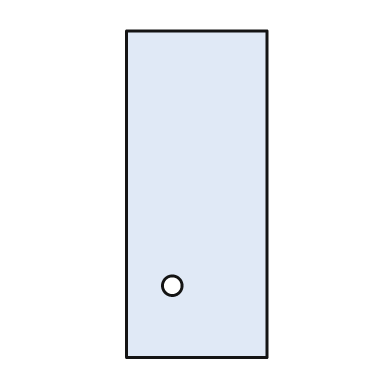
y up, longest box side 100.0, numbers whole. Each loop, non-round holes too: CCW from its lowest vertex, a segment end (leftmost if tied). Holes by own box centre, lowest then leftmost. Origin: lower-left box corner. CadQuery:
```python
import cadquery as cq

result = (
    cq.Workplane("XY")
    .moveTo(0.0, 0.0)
    .lineTo(43.0, 0.0)
    .lineTo(43.0, 100.0)
    .lineTo(0.0, 100.0)
    .close()
    .moveTo(14.0, 22.0)
    .circle(3.0)
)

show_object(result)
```